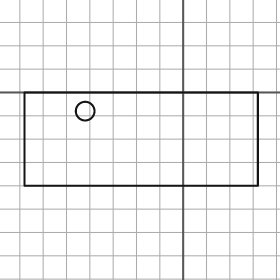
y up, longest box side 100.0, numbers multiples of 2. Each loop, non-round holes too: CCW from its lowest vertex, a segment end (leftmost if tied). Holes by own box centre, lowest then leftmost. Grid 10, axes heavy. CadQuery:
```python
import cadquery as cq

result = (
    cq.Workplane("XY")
    .moveTo(-68.0, -40.0)
    .lineTo(32.0, -40.0)
    .lineTo(32.0, 0.0)
    .lineTo(-68.0, 0.0)
    .close()
    .moveTo(-42.0, -8.0)
    .circle(4.0)
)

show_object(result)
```